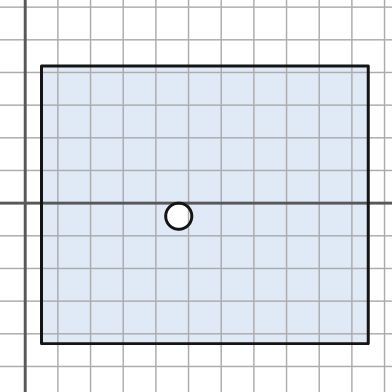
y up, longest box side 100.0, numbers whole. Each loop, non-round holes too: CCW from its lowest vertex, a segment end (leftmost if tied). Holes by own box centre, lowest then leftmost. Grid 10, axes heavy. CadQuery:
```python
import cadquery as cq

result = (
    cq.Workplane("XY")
    .moveTo(5.0, -43.0)
    .lineTo(105.0, -43.0)
    .lineTo(105.0, 42.0)
    .lineTo(5.0, 42.0)
    .close()
    .moveTo(47.0, -4.0)
    .circle(4.0)
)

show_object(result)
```